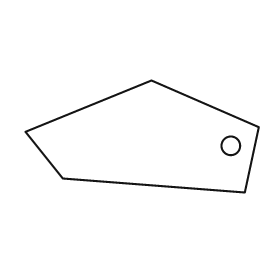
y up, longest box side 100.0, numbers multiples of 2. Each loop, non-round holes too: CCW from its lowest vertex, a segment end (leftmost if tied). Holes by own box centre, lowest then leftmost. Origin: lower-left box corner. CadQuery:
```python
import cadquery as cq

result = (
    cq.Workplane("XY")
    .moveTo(94.0, 0.0)
    .lineTo(100.0, 28.0)
    .lineTo(54.0, 48.0)
    .lineTo(0.0, 26.0)
    .lineTo(16.0, 6.0)
    .close()
    .moveTo(88.0, 20.0)
    .circle(4.0)
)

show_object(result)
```